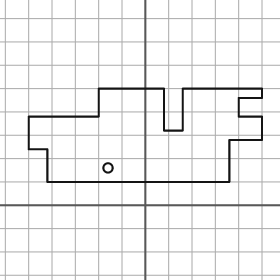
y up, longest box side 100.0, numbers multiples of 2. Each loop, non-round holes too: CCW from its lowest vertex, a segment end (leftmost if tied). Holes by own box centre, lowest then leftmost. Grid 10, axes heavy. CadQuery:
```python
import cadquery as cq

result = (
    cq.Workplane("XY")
    .moveTo(-42.0, 10.0)
    .lineTo(36.0, 10.0)
    .lineTo(36.0, 28.0)
    .lineTo(50.0, 28.0)
    .lineTo(50.0, 38.0)
    .lineTo(40.0, 38.0)
    .lineTo(40.0, 46.0)
    .lineTo(50.0, 46.0)
    .lineTo(50.0, 50.0)
    .lineTo(16.0, 50.0)
    .lineTo(16.0, 32.0)
    .lineTo(8.0, 32.0)
    .lineTo(8.0, 50.0)
    .lineTo(-20.0, 50.0)
    .lineTo(-20.0, 38.0)
    .lineTo(-50.0, 38.0)
    .lineTo(-50.0, 24.0)
    .lineTo(-42.0, 24.0)
    .close()
    .moveTo(-16.0, 16.0)
    .circle(2.0)
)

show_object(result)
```